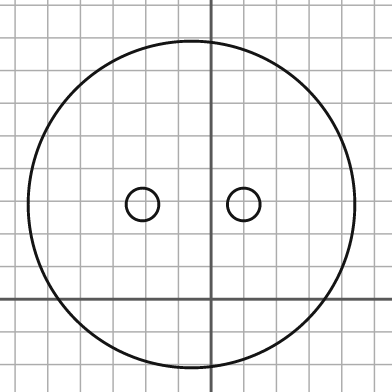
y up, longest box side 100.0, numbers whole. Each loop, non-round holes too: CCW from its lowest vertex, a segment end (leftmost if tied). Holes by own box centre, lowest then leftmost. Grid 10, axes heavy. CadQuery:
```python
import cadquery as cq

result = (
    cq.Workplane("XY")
    .moveTo(-6.0, 29.0)
    .circle(50.0)
    .moveTo(-21.0, 29.0)
    .circle(5.0)
    .moveTo(10.0, 29.0)
    .circle(5.0)
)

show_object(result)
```